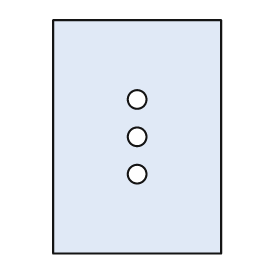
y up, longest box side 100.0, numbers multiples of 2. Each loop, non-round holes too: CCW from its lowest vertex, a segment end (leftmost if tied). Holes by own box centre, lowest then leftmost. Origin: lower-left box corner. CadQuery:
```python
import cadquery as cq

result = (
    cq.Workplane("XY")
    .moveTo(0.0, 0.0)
    .lineTo(72.0, 0.0)
    .lineTo(72.0, 100.0)
    .lineTo(0.0, 100.0)
    .close()
    .moveTo(36.0, 34.0)
    .circle(4.0)
    .moveTo(36.0, 50.0)
    .circle(4.0)
    .moveTo(36.0, 66.0)
    .circle(4.0)
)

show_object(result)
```